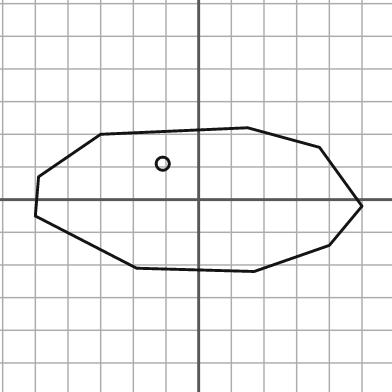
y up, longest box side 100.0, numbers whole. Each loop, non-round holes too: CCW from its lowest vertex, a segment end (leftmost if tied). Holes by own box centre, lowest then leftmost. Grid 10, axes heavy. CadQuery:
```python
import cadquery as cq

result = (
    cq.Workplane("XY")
    .moveTo(17.0, -22.0)
    .lineTo(40.0, -14.0)
    .lineTo(50.0, -2.0)
    .lineTo(37.0, 16.0)
    .lineTo(15.0, 22.0)
    .lineTo(-30.0, 20.0)
    .lineTo(-49.0, 7.0)
    .lineTo(-50.0, -5.0)
    .lineTo(-19.0, -21.0)
    .close()
    .moveTo(-11.0, 11.0)
    .circle(2.0)
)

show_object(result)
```